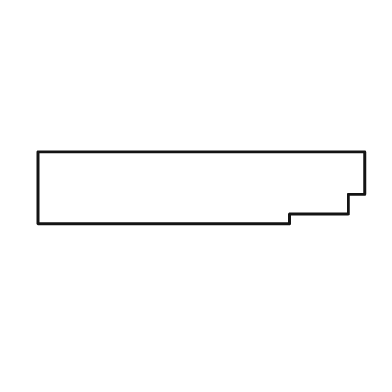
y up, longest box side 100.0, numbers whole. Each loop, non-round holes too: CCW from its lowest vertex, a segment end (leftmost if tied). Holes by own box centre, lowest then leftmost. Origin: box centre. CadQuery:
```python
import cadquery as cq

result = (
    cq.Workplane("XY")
    .moveTo(-50.0, -11.0)
    .lineTo(27.0, -11.0)
    .lineTo(27.0, -8.0)
    .lineTo(45.0, -8.0)
    .lineTo(45.0, -2.0)
    .lineTo(50.0, -2.0)
    .lineTo(50.0, 11.0)
    .lineTo(-50.0, 11.0)
    .close()
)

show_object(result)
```